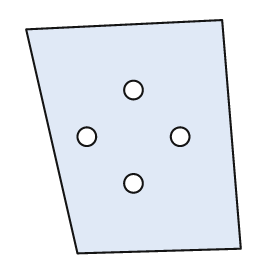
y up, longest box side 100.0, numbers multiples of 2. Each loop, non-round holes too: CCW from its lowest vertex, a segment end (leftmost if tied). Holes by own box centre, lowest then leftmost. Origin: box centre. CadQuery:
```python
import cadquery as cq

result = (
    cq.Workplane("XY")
    .moveTo(-24.0, -50.0)
    .lineTo(46.0, -48.0)
    .lineTo(38.0, 50.0)
    .lineTo(-46.0, 46.0)
    .close()
    .moveTo(0.0, -20.0)
    .circle(4.0)
    .moveTo(-20.0, 0.0)
    .circle(4.0)
    .moveTo(20.0, 0.0)
    .circle(4.0)
    .moveTo(0.0, 20.0)
    .circle(4.0)
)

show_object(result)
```